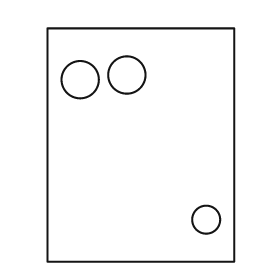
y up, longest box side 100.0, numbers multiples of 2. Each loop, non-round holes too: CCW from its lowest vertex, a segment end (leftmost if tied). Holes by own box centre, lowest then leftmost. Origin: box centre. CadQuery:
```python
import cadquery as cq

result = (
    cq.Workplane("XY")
    .moveTo(-40.0, -50.0)
    .lineTo(40.0, -50.0)
    .lineTo(40.0, 50.0)
    .lineTo(-40.0, 50.0)
    .close()
    .moveTo(28.0, -32.0)
    .circle(6.0)
    .moveTo(-26.0, 28.0)
    .circle(8.0)
    .moveTo(-6.0, 30.0)
    .circle(8.0)
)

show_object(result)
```